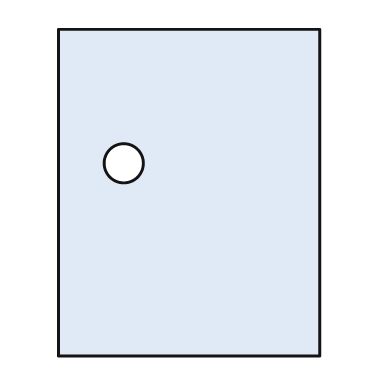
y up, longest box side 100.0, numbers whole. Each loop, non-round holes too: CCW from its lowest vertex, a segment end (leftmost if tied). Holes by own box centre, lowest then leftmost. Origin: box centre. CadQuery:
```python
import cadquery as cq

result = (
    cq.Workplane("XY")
    .moveTo(-40.0, -50.0)
    .lineTo(40.0, -50.0)
    .lineTo(40.0, 50.0)
    .lineTo(-40.0, 50.0)
    .close()
    .moveTo(-20.0, 9.0)
    .circle(6.0)
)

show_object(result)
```